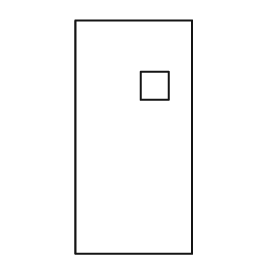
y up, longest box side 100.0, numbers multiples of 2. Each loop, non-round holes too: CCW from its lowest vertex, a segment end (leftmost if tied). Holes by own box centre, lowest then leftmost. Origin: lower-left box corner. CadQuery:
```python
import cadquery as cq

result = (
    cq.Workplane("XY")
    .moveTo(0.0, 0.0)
    .lineTo(50.0, 0.0)
    .lineTo(50.0, 100.0)
    .lineTo(0.0, 100.0)
    .close()
    .moveTo(28.0, 66.0)
    .lineTo(40.0, 66.0)
    .lineTo(40.0, 78.0)
    .lineTo(28.0, 78.0)
    .close()
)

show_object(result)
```